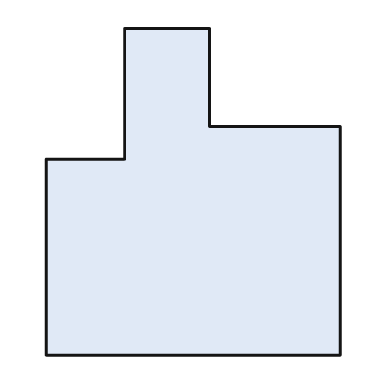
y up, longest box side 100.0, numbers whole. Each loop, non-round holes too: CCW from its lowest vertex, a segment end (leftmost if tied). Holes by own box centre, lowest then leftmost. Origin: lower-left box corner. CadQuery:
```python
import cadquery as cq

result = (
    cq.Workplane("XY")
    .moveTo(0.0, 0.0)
    .lineTo(90.0, 0.0)
    .lineTo(90.0, 70.0)
    .lineTo(50.0, 70.0)
    .lineTo(50.0, 100.0)
    .lineTo(24.0, 100.0)
    .lineTo(24.0, 60.0)
    .lineTo(0.0, 60.0)
    .close()
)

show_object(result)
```